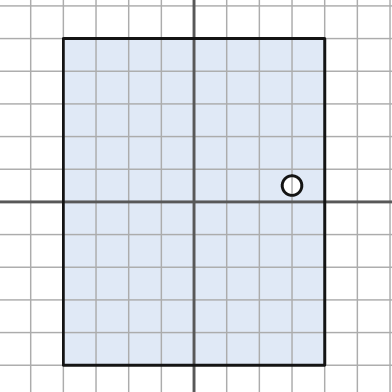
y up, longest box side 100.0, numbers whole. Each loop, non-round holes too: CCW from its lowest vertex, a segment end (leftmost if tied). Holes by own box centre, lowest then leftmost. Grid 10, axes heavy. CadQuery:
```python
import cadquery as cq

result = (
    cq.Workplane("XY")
    .moveTo(-40.0, -50.0)
    .lineTo(40.0, -50.0)
    .lineTo(40.0, 50.0)
    .lineTo(-40.0, 50.0)
    .close()
    .moveTo(30.0, 5.0)
    .circle(3.0)
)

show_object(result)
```